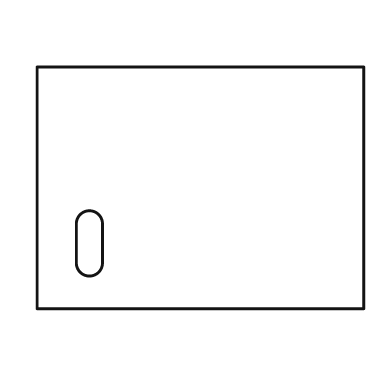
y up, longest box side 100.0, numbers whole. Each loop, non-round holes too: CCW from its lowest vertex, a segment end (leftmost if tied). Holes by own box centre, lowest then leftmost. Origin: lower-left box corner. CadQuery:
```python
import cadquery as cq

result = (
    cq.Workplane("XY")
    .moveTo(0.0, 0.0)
    .lineTo(100.0, 0.0)
    .lineTo(100.0, 74.0)
    .lineTo(0.0, 74.0)
    .close()
    .moveTo(12.0, 14.0)
    .threePointArc((16.0, 10.0), (20.0, 14.0))
    .lineTo(20.0, 26.0)
    .threePointArc((16.0, 30.0), (12.0, 26.0))
    .close()
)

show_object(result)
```